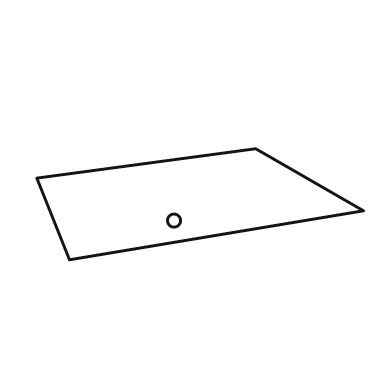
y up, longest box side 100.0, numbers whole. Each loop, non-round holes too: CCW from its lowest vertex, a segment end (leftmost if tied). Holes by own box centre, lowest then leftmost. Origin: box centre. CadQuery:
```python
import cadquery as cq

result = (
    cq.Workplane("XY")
    .moveTo(-40.0, -17.0)
    .lineTo(50.0, -2.0)
    .lineTo(17.0, 17.0)
    .lineTo(-50.0, 8.0)
    .close()
    .moveTo(-8.0, -5.0)
    .circle(2.0)
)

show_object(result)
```